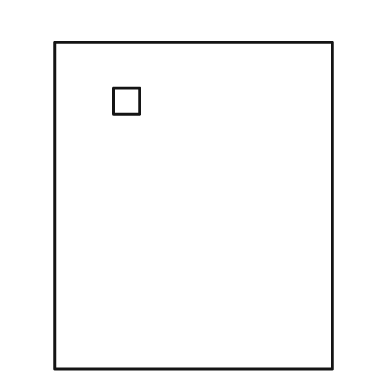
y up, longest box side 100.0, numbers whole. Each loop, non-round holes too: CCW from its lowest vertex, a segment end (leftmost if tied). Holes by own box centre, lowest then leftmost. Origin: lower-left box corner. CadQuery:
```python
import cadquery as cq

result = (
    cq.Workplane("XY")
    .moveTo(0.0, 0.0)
    .lineTo(85.0, 0.0)
    .lineTo(85.0, 100.0)
    .lineTo(0.0, 100.0)
    .close()
    .moveTo(18.0, 78.0)
    .lineTo(26.0, 78.0)
    .lineTo(26.0, 86.0)
    .lineTo(18.0, 86.0)
    .close()
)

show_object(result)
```